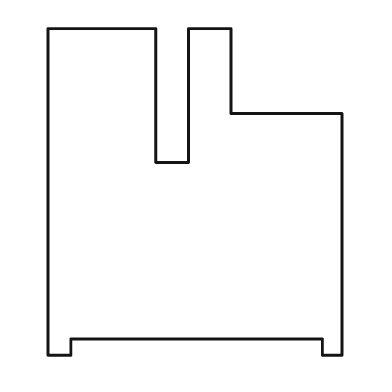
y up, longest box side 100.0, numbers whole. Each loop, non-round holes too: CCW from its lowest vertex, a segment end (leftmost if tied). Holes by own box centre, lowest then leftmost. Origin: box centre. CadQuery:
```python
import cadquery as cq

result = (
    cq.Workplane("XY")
    .moveTo(-45.0, -50.0)
    .lineTo(-38.0, -50.0)
    .lineTo(-38.0, -45.0)
    .lineTo(39.0, -45.0)
    .lineTo(39.0, -50.0)
    .lineTo(45.0, -50.0)
    .lineTo(45.0, 24.0)
    .lineTo(11.0, 24.0)
    .lineTo(11.0, 50.0)
    .lineTo(-2.0, 50.0)
    .lineTo(-2.0, 9.0)
    .lineTo(-12.0, 9.0)
    .lineTo(-12.0, 50.0)
    .lineTo(-45.0, 50.0)
    .close()
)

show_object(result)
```